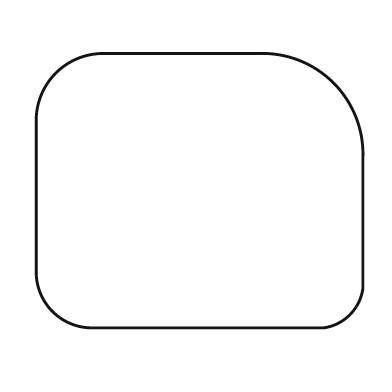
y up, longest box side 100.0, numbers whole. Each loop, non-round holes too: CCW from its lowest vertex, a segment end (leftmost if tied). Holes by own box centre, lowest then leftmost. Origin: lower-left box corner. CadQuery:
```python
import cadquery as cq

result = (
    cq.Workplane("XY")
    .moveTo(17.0, 0.0)
    .lineTo(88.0, 0.0)
    .threePointArc((96.0, 4.0), (100.0, 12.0))
    .lineTo(100.0, 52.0)
    .threePointArc((91.0, 75.0), (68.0, 84.0))
    .lineTo(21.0, 84.0)
    .threePointArc((6.0, 78.0), (0.0, 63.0))
    .lineTo(0.0, 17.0)
    .threePointArc((5.0, 5.0), (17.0, 0.0))
    .close()
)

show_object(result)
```